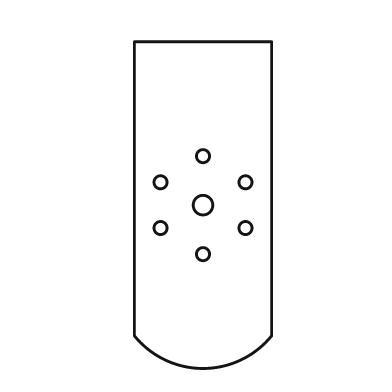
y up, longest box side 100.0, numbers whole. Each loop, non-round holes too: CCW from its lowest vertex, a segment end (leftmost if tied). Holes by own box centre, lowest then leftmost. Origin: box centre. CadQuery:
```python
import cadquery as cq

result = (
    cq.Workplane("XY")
    .moveTo(-21.0, -40.0)
    .threePointArc((0.0, -50.0), (21.0, -40.0))
    .lineTo(21.0, 50.0)
    .lineTo(-21.0, 50.0)
    .close()
    .moveTo(0.0, -15.0)
    .circle(2.0)
    .moveTo(-13.0, -7.0)
    .circle(2.0)
    .moveTo(13.0, -7.0)
    .circle(2.0)
    .moveTo(0.0, 0.0)
    .circle(3.0)
    .moveTo(-13.0, 7.0)
    .circle(2.0)
    .moveTo(13.0, 7.0)
    .circle(2.0)
    .moveTo(0.0, 15.0)
    .circle(2.0)
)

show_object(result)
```